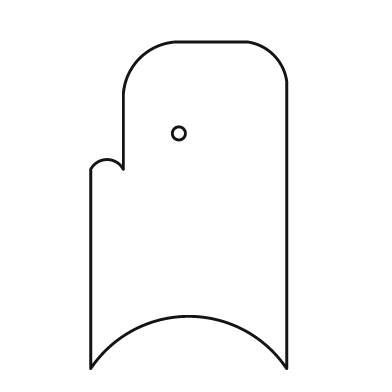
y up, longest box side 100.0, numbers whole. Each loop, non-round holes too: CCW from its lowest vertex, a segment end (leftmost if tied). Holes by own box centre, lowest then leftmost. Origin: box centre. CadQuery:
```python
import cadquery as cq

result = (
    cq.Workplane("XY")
    .moveTo(-30.0, -50.0)
    .threePointArc((0.0, -34.0), (30.0, -50.0))
    .lineTo(30.0, 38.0)
    .threePointArc((26.0, 46.0), (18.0, 50.0))
    .lineTo(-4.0, 50.0)
    .threePointArc((-15.0, 45.0), (-20.0, 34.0))
    .lineTo(-20.0, 11.0)
    .threePointArc((-25.0, 14.0), (-30.0, 11.0))
    .close()
    .moveTo(-3.0, 22.0)
    .circle(2.0)
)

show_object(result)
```